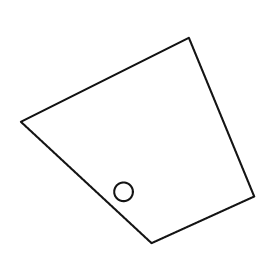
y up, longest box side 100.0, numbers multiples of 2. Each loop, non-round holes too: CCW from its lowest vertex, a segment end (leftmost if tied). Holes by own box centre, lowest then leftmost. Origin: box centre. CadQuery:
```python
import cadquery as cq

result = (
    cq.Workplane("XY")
    .moveTo(6.0, -44.0)
    .lineTo(50.0, -24.0)
    .lineTo(22.0, 44.0)
    .lineTo(-50.0, 8.0)
    .close()
    .moveTo(-6.0, -22.0)
    .circle(4.0)
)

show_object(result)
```